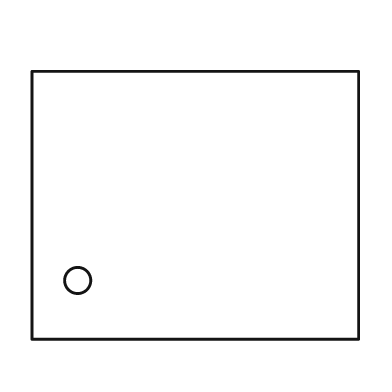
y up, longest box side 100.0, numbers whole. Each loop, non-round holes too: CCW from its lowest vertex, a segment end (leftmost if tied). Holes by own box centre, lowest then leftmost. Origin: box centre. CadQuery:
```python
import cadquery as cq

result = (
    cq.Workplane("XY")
    .moveTo(-50.0, -41.0)
    .lineTo(50.0, -41.0)
    .lineTo(50.0, 41.0)
    .lineTo(-50.0, 41.0)
    .close()
    .moveTo(-36.0, -23.0)
    .circle(4.0)
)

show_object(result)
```